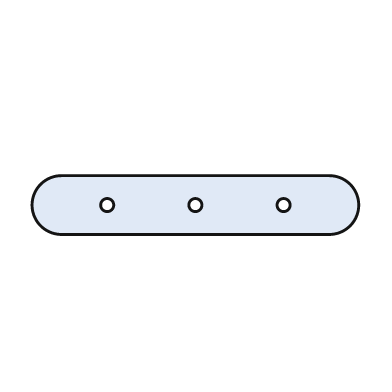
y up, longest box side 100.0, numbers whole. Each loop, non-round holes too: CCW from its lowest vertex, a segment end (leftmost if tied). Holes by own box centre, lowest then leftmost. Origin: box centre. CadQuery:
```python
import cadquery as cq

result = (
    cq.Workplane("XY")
    .moveTo(-41.0, -9.0)
    .lineTo(41.0, -9.0)
    .threePointArc((50.0, 0.0), (41.0, 9.0))
    .lineTo(-41.0, 9.0)
    .threePointArc((-50.0, 0.0), (-41.0, -9.0))
    .close()
    .moveTo(-27.0, 0.0)
    .circle(2.0)
    .moveTo(0.0, 0.0)
    .circle(2.0)
    .moveTo(27.0, 0.0)
    .circle(2.0)
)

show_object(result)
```